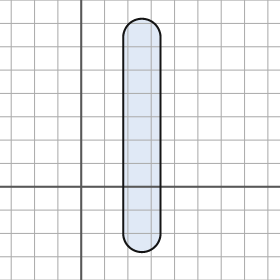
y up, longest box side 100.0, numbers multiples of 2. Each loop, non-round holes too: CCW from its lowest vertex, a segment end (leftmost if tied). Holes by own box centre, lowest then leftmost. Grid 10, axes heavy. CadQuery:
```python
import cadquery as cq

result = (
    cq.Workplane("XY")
    .moveTo(18.0, -20.0)
    .threePointArc((26.0, -28.0), (34.0, -20.0))
    .lineTo(34.0, 64.0)
    .threePointArc((26.0, 72.0), (18.0, 64.0))
    .close()
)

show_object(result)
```